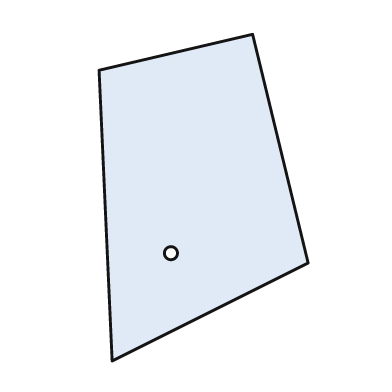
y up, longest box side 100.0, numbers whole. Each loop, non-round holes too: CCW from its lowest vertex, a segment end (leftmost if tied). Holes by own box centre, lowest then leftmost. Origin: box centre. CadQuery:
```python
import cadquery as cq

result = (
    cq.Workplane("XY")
    .moveTo(-28.0, -50.0)
    .lineTo(32.0, -20.0)
    .lineTo(15.0, 50.0)
    .lineTo(-32.0, 39.0)
    .close()
    .moveTo(-10.0, -17.0)
    .circle(2.0)
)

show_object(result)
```